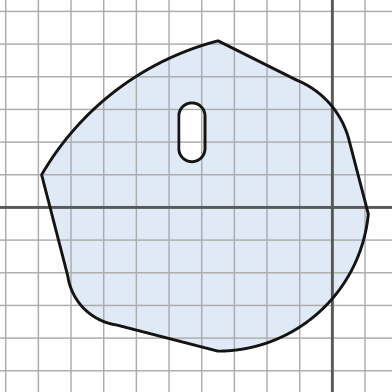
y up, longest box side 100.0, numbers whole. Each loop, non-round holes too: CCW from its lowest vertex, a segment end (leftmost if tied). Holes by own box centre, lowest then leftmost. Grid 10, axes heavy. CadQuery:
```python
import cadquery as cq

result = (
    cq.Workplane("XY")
    .moveTo(-35.0, -44.0)
    .threePointArc((-4.0, -32.0), (11.0, -2.0))
    .lineTo(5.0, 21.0)
    .threePointArc((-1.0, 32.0), (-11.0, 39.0))
    .lineTo(-35.0, 51.0)
    .threePointArc((-66.0, 36.0), (-89.0, 10.0))
    .lineTo(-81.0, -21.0)
    .threePointArc((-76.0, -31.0), (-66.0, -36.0))
    .close()
    .moveTo(-47.0, 18.0)
    .threePointArc((-43.0, 14.0), (-39.0, 18.0))
    .lineTo(-39.0, 28.0)
    .threePointArc((-43.0, 32.0), (-47.0, 28.0))
    .close()
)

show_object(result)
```